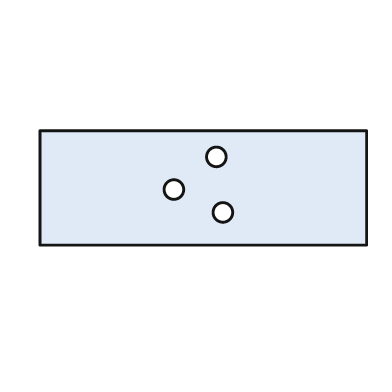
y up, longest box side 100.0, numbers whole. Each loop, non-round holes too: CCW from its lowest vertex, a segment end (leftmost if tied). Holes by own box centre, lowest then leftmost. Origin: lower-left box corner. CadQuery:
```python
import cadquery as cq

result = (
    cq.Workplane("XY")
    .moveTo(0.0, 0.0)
    .lineTo(100.0, 0.0)
    .lineTo(100.0, 35.0)
    .lineTo(0.0, 35.0)
    .close()
    .moveTo(56.0, 10.0)
    .circle(3.0)
    .moveTo(41.0, 17.0)
    .circle(3.0)
    .moveTo(54.0, 27.0)
    .circle(3.0)
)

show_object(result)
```